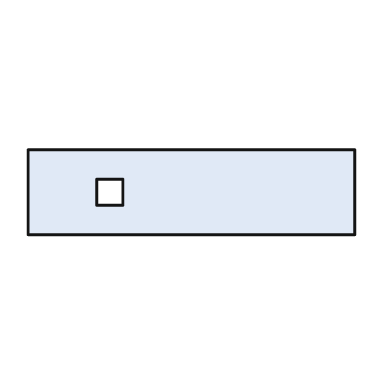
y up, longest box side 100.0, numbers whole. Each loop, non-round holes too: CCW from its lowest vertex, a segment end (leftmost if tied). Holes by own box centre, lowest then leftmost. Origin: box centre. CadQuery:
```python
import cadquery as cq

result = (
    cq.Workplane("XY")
    .moveTo(-50.0, -13.0)
    .lineTo(50.0, -13.0)
    .lineTo(50.0, 13.0)
    .lineTo(-50.0, 13.0)
    .close()
    .moveTo(-29.0, -4.0)
    .lineTo(-21.0, -4.0)
    .lineTo(-21.0, 4.0)
    .lineTo(-29.0, 4.0)
    .close()
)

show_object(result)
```